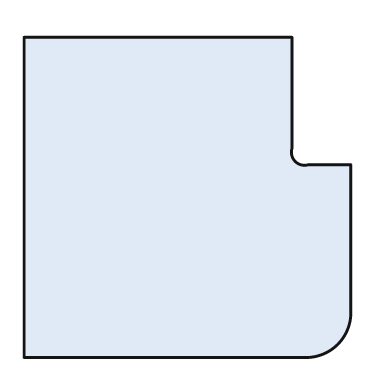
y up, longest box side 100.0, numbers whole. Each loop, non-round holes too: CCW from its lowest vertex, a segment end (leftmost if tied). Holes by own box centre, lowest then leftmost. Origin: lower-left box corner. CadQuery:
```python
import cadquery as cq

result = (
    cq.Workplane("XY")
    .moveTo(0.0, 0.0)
    .lineTo(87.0, 0.0)
    .threePointArc((96.0, 4.0), (100.0, 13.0))
    .lineTo(100.0, 59.0)
    .lineTo(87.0, 59.0)
    .threePointArc((83.0, 60.0), (82.0, 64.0))
    .lineTo(82.0, 98.0)
    .lineTo(0.0, 98.0)
    .close()
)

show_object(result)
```